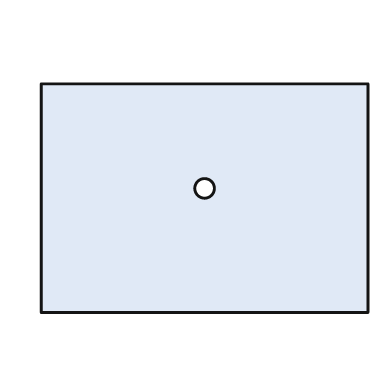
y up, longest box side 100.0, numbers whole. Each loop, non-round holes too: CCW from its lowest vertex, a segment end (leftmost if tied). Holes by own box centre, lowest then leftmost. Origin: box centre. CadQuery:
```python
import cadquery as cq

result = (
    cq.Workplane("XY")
    .moveTo(-50.0, -35.0)
    .lineTo(50.0, -35.0)
    .lineTo(50.0, 35.0)
    .lineTo(-50.0, 35.0)
    .close()
    .moveTo(0.0, 3.0)
    .circle(3.0)
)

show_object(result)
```